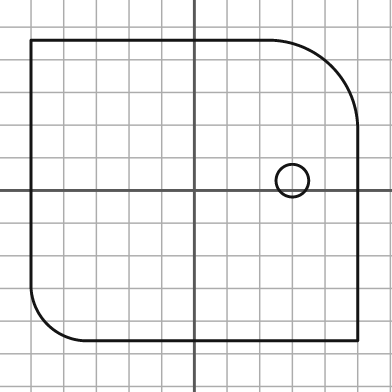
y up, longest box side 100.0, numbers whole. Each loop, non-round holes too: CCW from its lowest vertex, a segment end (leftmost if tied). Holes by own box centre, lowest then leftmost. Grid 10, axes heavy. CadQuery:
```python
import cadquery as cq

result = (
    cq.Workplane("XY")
    .moveTo(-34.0, -46.0)
    .lineTo(50.0, -46.0)
    .lineTo(50.0, 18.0)
    .threePointArc((42.0, 38.0), (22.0, 46.0))
    .lineTo(-50.0, 46.0)
    .lineTo(-50.0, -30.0)
    .threePointArc((-45.0, -41.0), (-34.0, -46.0))
    .close()
    .moveTo(30.0, 3.0)
    .circle(5.0)
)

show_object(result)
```